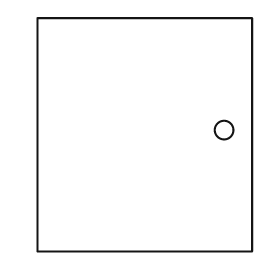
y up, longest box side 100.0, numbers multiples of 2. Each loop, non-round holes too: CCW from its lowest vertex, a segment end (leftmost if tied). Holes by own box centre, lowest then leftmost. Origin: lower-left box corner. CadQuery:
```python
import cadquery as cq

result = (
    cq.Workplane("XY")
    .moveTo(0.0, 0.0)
    .lineTo(92.0, 0.0)
    .lineTo(92.0, 100.0)
    .lineTo(0.0, 100.0)
    .close()
    .moveTo(80.0, 52.0)
    .circle(4.0)
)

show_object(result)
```